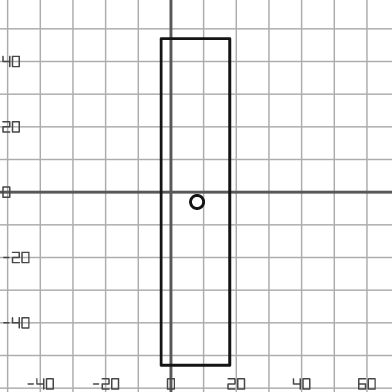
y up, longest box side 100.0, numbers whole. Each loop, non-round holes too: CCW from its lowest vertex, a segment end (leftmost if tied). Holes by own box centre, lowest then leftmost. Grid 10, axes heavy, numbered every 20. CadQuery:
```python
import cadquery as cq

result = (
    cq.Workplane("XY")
    .moveTo(-3.0, -53.0)
    .lineTo(18.0, -53.0)
    .lineTo(18.0, 47.0)
    .lineTo(-3.0, 47.0)
    .close()
    .moveTo(8.0, -3.0)
    .circle(2.0)
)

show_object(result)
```